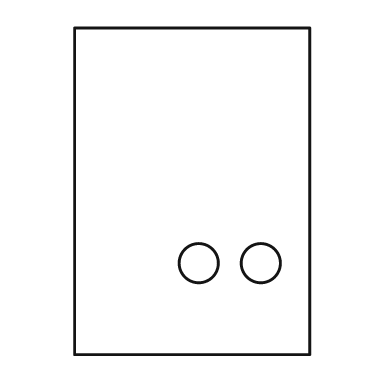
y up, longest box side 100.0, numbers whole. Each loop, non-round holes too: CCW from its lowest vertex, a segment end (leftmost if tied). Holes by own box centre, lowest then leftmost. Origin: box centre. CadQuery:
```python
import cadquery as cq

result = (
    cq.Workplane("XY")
    .moveTo(-36.0, -50.0)
    .lineTo(36.0, -50.0)
    .lineTo(36.0, 50.0)
    .lineTo(-36.0, 50.0)
    .close()
    .moveTo(2.0, -22.0)
    .circle(6.0)
    .moveTo(21.0, -22.0)
    .circle(6.0)
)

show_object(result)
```